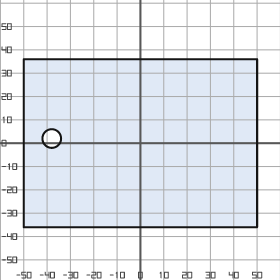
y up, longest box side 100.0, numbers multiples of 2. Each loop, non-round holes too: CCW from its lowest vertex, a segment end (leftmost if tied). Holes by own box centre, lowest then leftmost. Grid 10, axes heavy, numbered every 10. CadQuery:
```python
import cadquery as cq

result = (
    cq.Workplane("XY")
    .moveTo(-50.0, -36.0)
    .lineTo(50.0, -36.0)
    .lineTo(50.0, 36.0)
    .lineTo(-50.0, 36.0)
    .close()
    .moveTo(-38.0, 2.0)
    .circle(4.0)
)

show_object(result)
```